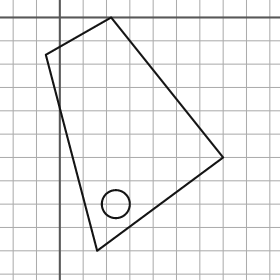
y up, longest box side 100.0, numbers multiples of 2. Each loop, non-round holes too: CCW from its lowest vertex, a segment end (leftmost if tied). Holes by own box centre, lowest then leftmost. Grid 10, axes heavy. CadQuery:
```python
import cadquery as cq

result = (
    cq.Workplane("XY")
    .moveTo(16.0, -100.0)
    .lineTo(70.0, -60.0)
    .lineTo(22.0, 0.0)
    .lineTo(-6.0, -16.0)
    .close()
    .moveTo(24.0, -80.0)
    .circle(6.0)
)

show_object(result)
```